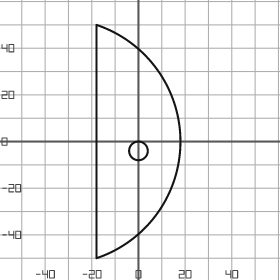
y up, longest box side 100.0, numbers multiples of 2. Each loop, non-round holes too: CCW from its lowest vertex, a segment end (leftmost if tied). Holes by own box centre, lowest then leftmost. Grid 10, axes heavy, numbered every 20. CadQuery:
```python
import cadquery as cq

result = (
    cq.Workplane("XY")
    .moveTo(-18.0, -50.0)
    .threePointArc((18.0, 0.0), (-18.0, 50.0))
    .close()
    .moveTo(0.0, -4.0)
    .circle(4.0)
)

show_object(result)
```